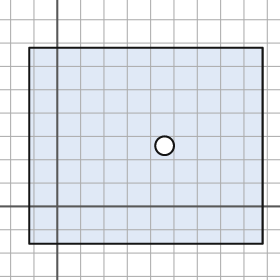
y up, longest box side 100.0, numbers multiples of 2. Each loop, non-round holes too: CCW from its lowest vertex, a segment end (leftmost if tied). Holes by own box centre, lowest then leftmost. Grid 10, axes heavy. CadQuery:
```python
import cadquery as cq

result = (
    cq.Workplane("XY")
    .moveTo(-12.0, -16.0)
    .lineTo(88.0, -16.0)
    .lineTo(88.0, 68.0)
    .lineTo(-12.0, 68.0)
    .close()
    .moveTo(46.0, 26.0)
    .circle(4.0)
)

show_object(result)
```